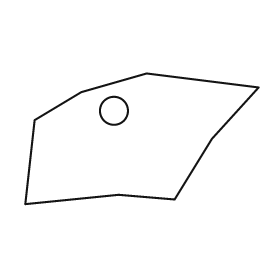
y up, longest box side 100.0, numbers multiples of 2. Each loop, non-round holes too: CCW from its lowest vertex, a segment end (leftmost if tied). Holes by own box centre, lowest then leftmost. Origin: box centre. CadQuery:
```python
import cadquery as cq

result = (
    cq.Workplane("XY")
    .moveTo(-50.0, -28.0)
    .lineTo(-10.0, -24.0)
    .lineTo(14.0, -26.0)
    .lineTo(30.0, 0.0)
    .lineTo(50.0, 22.0)
    .lineTo(2.0, 28.0)
    .lineTo(-26.0, 20.0)
    .lineTo(-46.0, 8.0)
    .close()
    .moveTo(-12.0, 12.0)
    .circle(6.0)
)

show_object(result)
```